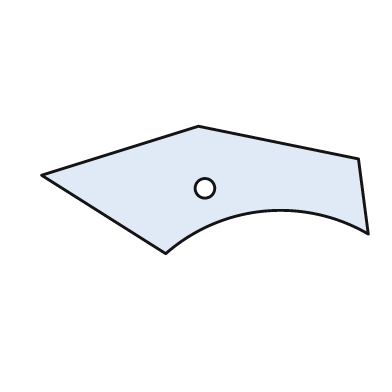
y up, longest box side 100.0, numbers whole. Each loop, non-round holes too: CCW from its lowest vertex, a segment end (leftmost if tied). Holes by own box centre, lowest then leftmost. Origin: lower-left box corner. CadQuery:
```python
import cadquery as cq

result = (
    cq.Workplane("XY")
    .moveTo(38.0, 0.0)
    .threePointArc((68.0, 13.0), (100.0, 6.0))
    .lineTo(97.0, 29.0)
    .lineTo(48.0, 39.0)
    .lineTo(0.0, 24.0)
    .close()
    .moveTo(50.0, 20.0)
    .circle(3.0)
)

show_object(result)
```